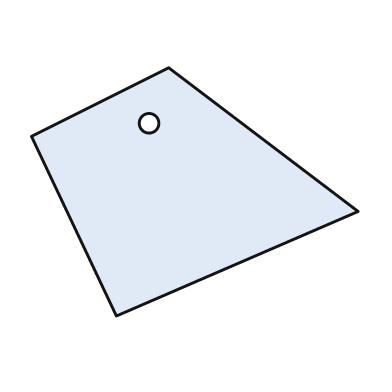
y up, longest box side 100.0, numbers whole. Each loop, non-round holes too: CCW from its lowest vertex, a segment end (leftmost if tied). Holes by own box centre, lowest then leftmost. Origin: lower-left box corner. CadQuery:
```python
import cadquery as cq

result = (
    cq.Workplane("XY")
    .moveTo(26.0, 0.0)
    .lineTo(100.0, 32.0)
    .lineTo(42.0, 76.0)
    .lineTo(0.0, 55.0)
    .close()
    .moveTo(36.0, 59.0)
    .circle(3.0)
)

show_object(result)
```